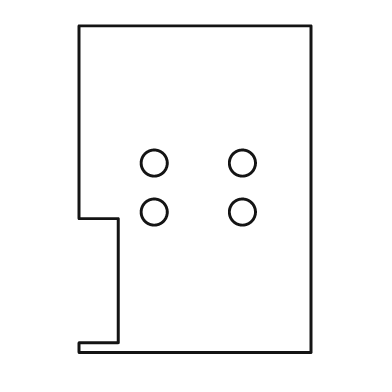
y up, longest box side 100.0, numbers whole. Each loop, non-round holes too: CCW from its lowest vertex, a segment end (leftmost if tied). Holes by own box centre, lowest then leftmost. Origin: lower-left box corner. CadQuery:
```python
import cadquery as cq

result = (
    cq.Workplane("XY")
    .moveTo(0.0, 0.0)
    .lineTo(71.0, 0.0)
    .lineTo(71.0, 100.0)
    .lineTo(0.0, 100.0)
    .lineTo(0.0, 41.0)
    .lineTo(12.0, 41.0)
    .lineTo(12.0, 3.0)
    .lineTo(0.0, 3.0)
    .close()
    .moveTo(23.0, 43.0)
    .circle(4.0)
    .moveTo(50.0, 43.0)
    .circle(4.0)
    .moveTo(23.0, 58.0)
    .circle(4.0)
    .moveTo(50.0, 58.0)
    .circle(4.0)
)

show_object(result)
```